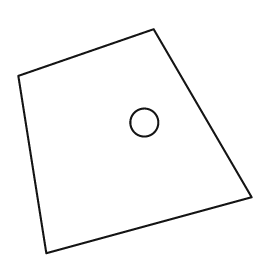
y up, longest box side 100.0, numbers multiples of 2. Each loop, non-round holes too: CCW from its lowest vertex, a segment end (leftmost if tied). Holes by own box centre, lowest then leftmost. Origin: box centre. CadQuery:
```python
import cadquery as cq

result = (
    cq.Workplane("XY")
    .moveTo(-38.0, -48.0)
    .lineTo(50.0, -24.0)
    .lineTo(8.0, 48.0)
    .lineTo(-50.0, 28.0)
    .close()
    .moveTo(4.0, 8.0)
    .circle(6.0)
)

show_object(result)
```